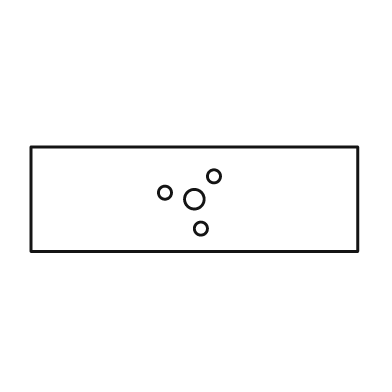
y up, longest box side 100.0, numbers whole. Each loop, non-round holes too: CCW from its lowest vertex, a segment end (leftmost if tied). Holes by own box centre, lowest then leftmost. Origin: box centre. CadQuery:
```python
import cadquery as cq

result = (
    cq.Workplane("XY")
    .moveTo(-50.0, -16.0)
    .lineTo(50.0, -16.0)
    .lineTo(50.0, 16.0)
    .lineTo(-50.0, 16.0)
    .close()
    .moveTo(2.0, -9.0)
    .circle(2.0)
    .moveTo(0.0, 0.0)
    .circle(3.0)
    .moveTo(-9.0, 2.0)
    .circle(2.0)
    .moveTo(6.0, 7.0)
    .circle(2.0)
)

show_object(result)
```